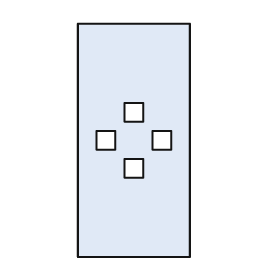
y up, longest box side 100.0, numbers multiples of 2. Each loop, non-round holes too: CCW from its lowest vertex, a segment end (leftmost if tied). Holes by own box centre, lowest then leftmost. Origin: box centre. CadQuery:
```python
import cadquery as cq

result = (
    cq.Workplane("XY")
    .moveTo(-24.0, -50.0)
    .lineTo(24.0, -50.0)
    .lineTo(24.0, 50.0)
    .lineTo(-24.0, 50.0)
    .close()
    .moveTo(-4.0, -16.0)
    .lineTo(4.0, -16.0)
    .lineTo(4.0, -8.0)
    .lineTo(-4.0, -8.0)
    .close()
    .moveTo(-16.0, -4.0)
    .lineTo(-8.0, -4.0)
    .lineTo(-8.0, 4.0)
    .lineTo(-16.0, 4.0)
    .close()
    .moveTo(8.0, -4.0)
    .lineTo(16.0, -4.0)
    .lineTo(16.0, 4.0)
    .lineTo(8.0, 4.0)
    .close()
    .moveTo(-4.0, 8.0)
    .lineTo(4.0, 8.0)
    .lineTo(4.0, 16.0)
    .lineTo(-4.0, 16.0)
    .close()
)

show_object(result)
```